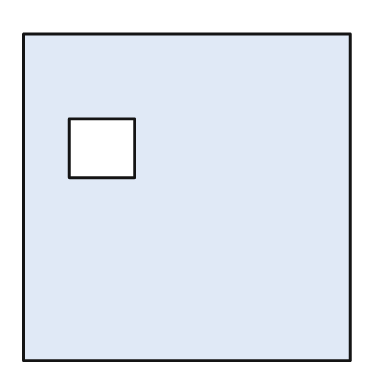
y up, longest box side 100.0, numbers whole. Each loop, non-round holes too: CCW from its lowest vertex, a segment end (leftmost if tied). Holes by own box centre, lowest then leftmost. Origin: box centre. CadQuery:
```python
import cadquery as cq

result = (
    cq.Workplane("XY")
    .moveTo(-50.0, -50.0)
    .lineTo(50.0, -50.0)
    .lineTo(50.0, 50.0)
    .lineTo(-50.0, 50.0)
    .close()
    .moveTo(-36.0, 6.0)
    .lineTo(-16.0, 6.0)
    .lineTo(-16.0, 24.0)
    .lineTo(-36.0, 24.0)
    .close()
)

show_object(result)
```